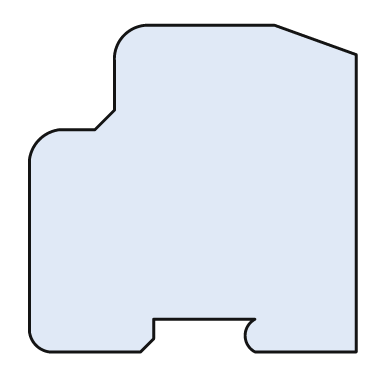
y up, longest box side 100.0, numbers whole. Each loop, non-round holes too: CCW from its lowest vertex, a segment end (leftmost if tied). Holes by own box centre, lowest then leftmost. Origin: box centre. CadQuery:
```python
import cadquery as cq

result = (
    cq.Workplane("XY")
    .moveTo(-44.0, -50.0)
    .lineTo(-16.0, -50.0)
    .lineTo(-12.0, -46.0)
    .lineTo(-12.0, -40.0)
    .lineTo(19.0, -40.0)
    .threePointArc((16.0, -45.0), (19.0, -50.0))
    .lineTo(50.0, -50.0)
    .lineTo(50.0, 41.0)
    .lineTo(25.0, 50.0)
    .lineTo(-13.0, 50.0)
    .threePointArc((-21.0, 47.0), (-24.0, 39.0))
    .lineTo(-24.0, 24.0)
    .lineTo(-30.0, 18.0)
    .lineTo(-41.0, 18.0)
    .threePointArc((-47.0, 15.0), (-50.0, 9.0))
    .lineTo(-50.0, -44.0)
    .threePointArc((-48.0, -48.0), (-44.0, -50.0))
    .close()
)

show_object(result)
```